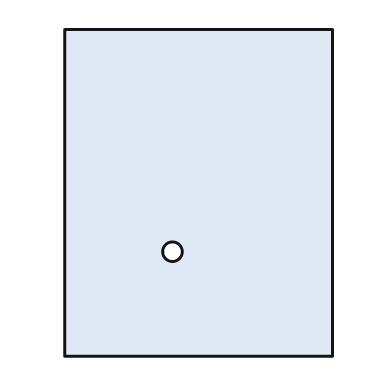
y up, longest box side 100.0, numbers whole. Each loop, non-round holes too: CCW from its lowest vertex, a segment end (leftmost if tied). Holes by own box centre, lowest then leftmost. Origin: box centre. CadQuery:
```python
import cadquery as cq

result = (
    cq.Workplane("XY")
    .moveTo(-41.0, -50.0)
    .lineTo(41.0, -50.0)
    .lineTo(41.0, 50.0)
    .lineTo(-41.0, 50.0)
    .close()
    .moveTo(-8.0, -18.0)
    .circle(3.0)
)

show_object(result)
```